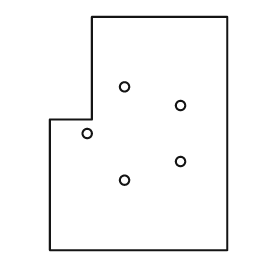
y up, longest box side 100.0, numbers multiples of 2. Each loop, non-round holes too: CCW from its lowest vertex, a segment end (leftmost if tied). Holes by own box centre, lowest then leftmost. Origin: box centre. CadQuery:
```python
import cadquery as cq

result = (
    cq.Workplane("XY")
    .moveTo(-38.0, -50.0)
    .lineTo(38.0, -50.0)
    .lineTo(38.0, 50.0)
    .lineTo(-20.0, 50.0)
    .lineTo(-20.0, 6.0)
    .lineTo(-38.0, 6.0)
    .close()
    .moveTo(-6.0, -20.0)
    .circle(2.0)
    .moveTo(18.0, -12.0)
    .circle(2.0)
    .moveTo(-22.0, 0.0)
    .circle(2.0)
    .moveTo(18.0, 12.0)
    .circle(2.0)
    .moveTo(-6.0, 20.0)
    .circle(2.0)
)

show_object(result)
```